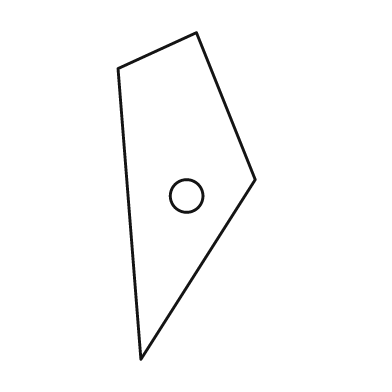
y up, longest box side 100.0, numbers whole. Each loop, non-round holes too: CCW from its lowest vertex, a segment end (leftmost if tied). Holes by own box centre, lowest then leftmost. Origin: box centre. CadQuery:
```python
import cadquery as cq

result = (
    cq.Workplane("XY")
    .moveTo(-14.0, -50.0)
    .lineTo(21.0, 5.0)
    .lineTo(3.0, 50.0)
    .lineTo(-21.0, 39.0)
    .close()
    .moveTo(0.0, 0.0)
    .circle(5.0)
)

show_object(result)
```